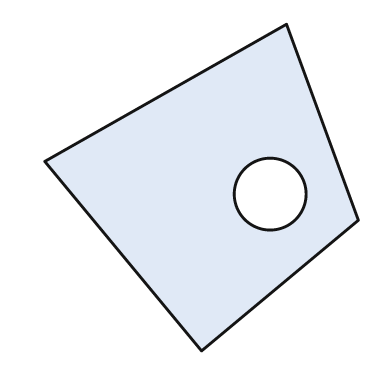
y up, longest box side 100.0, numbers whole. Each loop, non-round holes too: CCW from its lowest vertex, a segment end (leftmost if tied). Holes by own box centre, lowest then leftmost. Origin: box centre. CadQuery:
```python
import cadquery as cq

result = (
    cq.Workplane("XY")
    .moveTo(0.0, -50.0)
    .lineTo(48.0, -10.0)
    .lineTo(26.0, 50.0)
    .lineTo(-48.0, 8.0)
    .close()
    .moveTo(21.0, -2.0)
    .circle(11.0)
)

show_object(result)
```